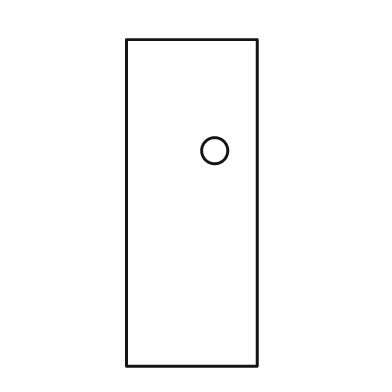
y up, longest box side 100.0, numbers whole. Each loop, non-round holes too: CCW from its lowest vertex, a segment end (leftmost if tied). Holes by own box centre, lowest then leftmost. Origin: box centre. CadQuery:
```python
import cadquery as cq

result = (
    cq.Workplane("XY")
    .moveTo(-20.0, -50.0)
    .lineTo(20.0, -50.0)
    .lineTo(20.0, 50.0)
    .lineTo(-20.0, 50.0)
    .close()
    .moveTo(7.0, 16.0)
    .circle(4.0)
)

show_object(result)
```